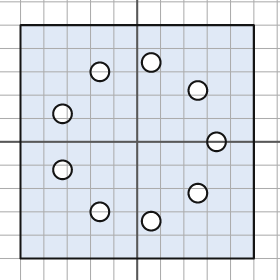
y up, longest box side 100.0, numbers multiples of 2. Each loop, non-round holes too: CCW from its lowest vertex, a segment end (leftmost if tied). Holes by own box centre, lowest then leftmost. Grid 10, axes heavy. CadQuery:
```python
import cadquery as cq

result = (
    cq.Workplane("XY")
    .moveTo(-50.0, -50.0)
    .lineTo(50.0, -50.0)
    .lineTo(50.0, 50.0)
    .lineTo(-50.0, 50.0)
    .close()
    .moveTo(6.0, -34.0)
    .circle(4.0)
    .moveTo(-16.0, -30.0)
    .circle(4.0)
    .moveTo(26.0, -22.0)
    .circle(4.0)
    .moveTo(-32.0, -12.0)
    .circle(4.0)
    .moveTo(34.0, 0.0)
    .circle(4.0)
    .moveTo(-32.0, 12.0)
    .circle(4.0)
    .moveTo(26.0, 22.0)
    .circle(4.0)
    .moveTo(-16.0, 30.0)
    .circle(4.0)
    .moveTo(6.0, 34.0)
    .circle(4.0)
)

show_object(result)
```